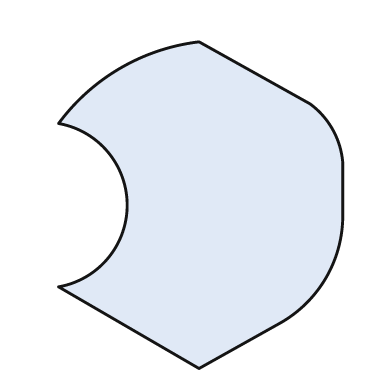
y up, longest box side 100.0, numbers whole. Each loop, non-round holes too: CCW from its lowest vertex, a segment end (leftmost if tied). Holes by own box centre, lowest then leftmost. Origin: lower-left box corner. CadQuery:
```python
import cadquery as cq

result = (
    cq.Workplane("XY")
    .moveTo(43.0, 0.0)
    .lineTo(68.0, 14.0)
    .threePointArc((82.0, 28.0), (87.0, 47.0))
    .lineTo(87.0, 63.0)
    .threePointArc((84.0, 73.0), (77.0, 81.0))
    .lineTo(43.0, 100.0)
    .threePointArc((19.0, 92.0), (0.0, 75.0))
    .threePointArc((21.0, 50.0), (0.0, 25.0))
    .close()
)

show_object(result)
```